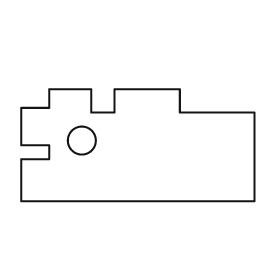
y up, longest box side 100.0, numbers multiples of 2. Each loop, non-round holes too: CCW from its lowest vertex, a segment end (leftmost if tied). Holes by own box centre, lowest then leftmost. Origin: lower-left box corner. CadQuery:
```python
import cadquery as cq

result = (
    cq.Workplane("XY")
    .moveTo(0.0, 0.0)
    .lineTo(100.0, 0.0)
    .lineTo(100.0, 38.0)
    .lineTo(68.0, 38.0)
    .lineTo(68.0, 48.0)
    .lineTo(40.0, 48.0)
    .lineTo(40.0, 38.0)
    .lineTo(30.0, 38.0)
    .lineTo(30.0, 48.0)
    .lineTo(12.0, 48.0)
    .lineTo(12.0, 40.0)
    .lineTo(0.0, 40.0)
    .lineTo(0.0, 24.0)
    .lineTo(12.0, 24.0)
    .lineTo(12.0, 18.0)
    .lineTo(0.0, 18.0)
    .close()
    .moveTo(26.0, 26.0)
    .circle(6.0)
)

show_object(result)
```